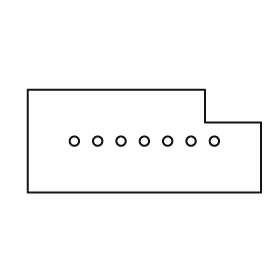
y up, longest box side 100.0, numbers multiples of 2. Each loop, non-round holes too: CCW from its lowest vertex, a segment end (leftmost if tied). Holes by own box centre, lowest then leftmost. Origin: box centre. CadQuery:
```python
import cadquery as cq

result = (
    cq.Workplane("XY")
    .moveTo(-50.0, -22.0)
    .lineTo(50.0, -22.0)
    .lineTo(50.0, 8.0)
    .lineTo(26.0, 8.0)
    .lineTo(26.0, 22.0)
    .lineTo(-50.0, 22.0)
    .close()
    .moveTo(-30.0, 0.0)
    .circle(2.0)
    .moveTo(-20.0, 0.0)
    .circle(2.0)
    .moveTo(-10.0, 0.0)
    .circle(2.0)
    .moveTo(0.0, 0.0)
    .circle(2.0)
    .moveTo(10.0, 0.0)
    .circle(2.0)
    .moveTo(20.0, 0.0)
    .circle(2.0)
    .moveTo(30.0, 0.0)
    .circle(2.0)
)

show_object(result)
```